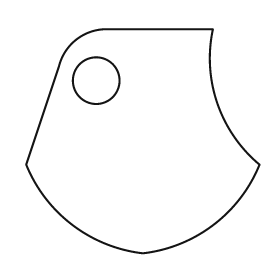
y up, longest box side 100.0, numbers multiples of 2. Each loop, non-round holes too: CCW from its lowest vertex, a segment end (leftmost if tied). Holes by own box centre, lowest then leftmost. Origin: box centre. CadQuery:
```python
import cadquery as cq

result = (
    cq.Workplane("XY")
    .moveTo(0.0, -48.0)
    .threePointArc((30.0, -36.0), (50.0, -10.0))
    .threePointArc((32.0, 16.0), (30.0, 48.0))
    .lineTo(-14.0, 48.0)
    .threePointArc((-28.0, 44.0), (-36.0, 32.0))
    .lineTo(-50.0, -10.0)
    .threePointArc((-30.0, -36.0), (0.0, -48.0))
    .close()
    .moveTo(-20.0, 26.0)
    .circle(10.0)
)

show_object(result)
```